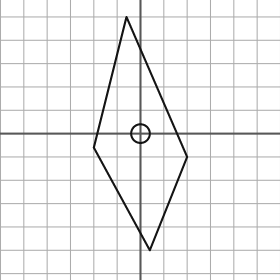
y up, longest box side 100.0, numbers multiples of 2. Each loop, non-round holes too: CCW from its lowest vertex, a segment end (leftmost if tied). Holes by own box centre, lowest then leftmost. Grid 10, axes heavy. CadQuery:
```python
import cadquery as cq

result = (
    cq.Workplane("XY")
    .moveTo(4.0, -50.0)
    .lineTo(20.0, -10.0)
    .lineTo(-6.0, 50.0)
    .lineTo(-20.0, -6.0)
    .close()
    .moveTo(0.0, 0.0)
    .circle(4.0)
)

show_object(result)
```